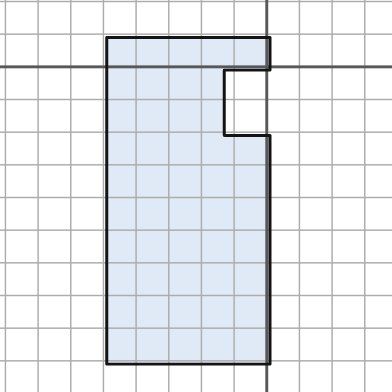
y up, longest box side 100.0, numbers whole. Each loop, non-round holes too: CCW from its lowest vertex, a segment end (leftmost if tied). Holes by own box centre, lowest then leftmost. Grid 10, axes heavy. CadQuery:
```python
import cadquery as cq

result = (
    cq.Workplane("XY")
    .moveTo(-49.0, -91.0)
    .lineTo(1.0, -91.0)
    .lineTo(1.0, -21.0)
    .lineTo(-13.0, -21.0)
    .lineTo(-13.0, -1.0)
    .lineTo(1.0, -1.0)
    .lineTo(1.0, 9.0)
    .lineTo(-49.0, 9.0)
    .close()
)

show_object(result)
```